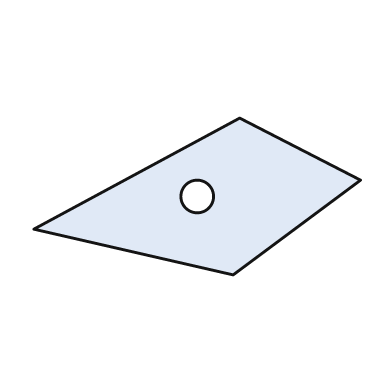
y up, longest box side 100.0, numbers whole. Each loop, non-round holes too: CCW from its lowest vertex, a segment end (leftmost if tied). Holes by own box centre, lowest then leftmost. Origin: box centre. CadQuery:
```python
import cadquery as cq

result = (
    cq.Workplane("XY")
    .moveTo(11.0, -24.0)
    .lineTo(50.0, 5.0)
    .lineTo(13.0, 24.0)
    .lineTo(-50.0, -10.0)
    .close()
    .moveTo(0.0, 0.0)
    .circle(5.0)
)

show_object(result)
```